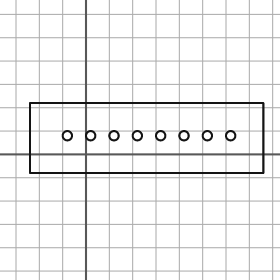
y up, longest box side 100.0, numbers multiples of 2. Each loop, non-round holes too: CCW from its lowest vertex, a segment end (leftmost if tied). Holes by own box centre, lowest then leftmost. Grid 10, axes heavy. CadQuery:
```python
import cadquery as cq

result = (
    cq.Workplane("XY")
    .moveTo(-24.0, -8.0)
    .lineTo(76.0, -8.0)
    .lineTo(76.0, 22.0)
    .lineTo(-24.0, 22.0)
    .close()
    .moveTo(-8.0, 8.0)
    .circle(2.0)
    .moveTo(2.0, 8.0)
    .circle(2.0)
    .moveTo(12.0, 8.0)
    .circle(2.0)
    .moveTo(22.0, 8.0)
    .circle(2.0)
    .moveTo(32.0, 8.0)
    .circle(2.0)
    .moveTo(42.0, 8.0)
    .circle(2.0)
    .moveTo(52.0, 8.0)
    .circle(2.0)
    .moveTo(62.0, 8.0)
    .circle(2.0)
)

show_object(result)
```